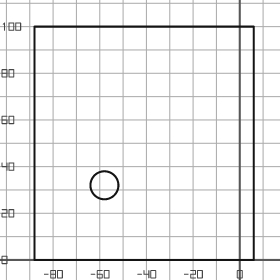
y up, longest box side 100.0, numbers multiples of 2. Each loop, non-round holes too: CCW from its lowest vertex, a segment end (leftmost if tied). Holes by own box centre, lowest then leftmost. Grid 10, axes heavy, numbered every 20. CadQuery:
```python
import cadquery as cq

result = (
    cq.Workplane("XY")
    .moveTo(-88.0, 0.0)
    .lineTo(6.0, 0.0)
    .lineTo(6.0, 100.0)
    .lineTo(-88.0, 100.0)
    .close()
    .moveTo(-58.0, 32.0)
    .circle(6.0)
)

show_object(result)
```